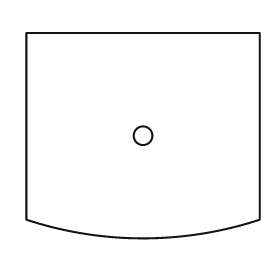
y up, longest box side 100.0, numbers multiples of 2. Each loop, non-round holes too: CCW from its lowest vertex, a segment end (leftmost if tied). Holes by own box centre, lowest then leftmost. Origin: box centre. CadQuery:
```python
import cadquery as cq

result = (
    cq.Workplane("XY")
    .moveTo(-50.0, -36.0)
    .threePointArc((0.0, -44.0), (50.0, -36.0))
    .lineTo(50.0, 44.0)
    .lineTo(-50.0, 44.0)
    .close()
    .moveTo(0.0, 0.0)
    .circle(4.0)
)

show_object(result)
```